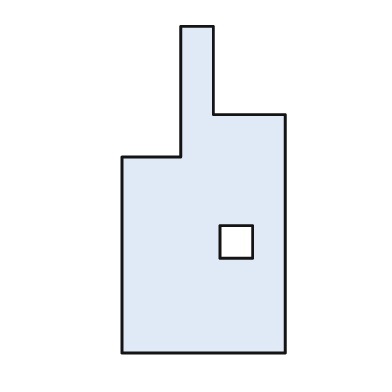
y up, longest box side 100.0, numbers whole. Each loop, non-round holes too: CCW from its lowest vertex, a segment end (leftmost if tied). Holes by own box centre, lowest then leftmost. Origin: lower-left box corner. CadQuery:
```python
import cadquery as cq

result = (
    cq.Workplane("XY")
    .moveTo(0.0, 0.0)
    .lineTo(50.0, 0.0)
    .lineTo(50.0, 73.0)
    .lineTo(28.0, 73.0)
    .lineTo(28.0, 100.0)
    .lineTo(18.0, 100.0)
    .lineTo(18.0, 60.0)
    .lineTo(0.0, 60.0)
    .close()
    .moveTo(30.0, 29.0)
    .lineTo(40.0, 29.0)
    .lineTo(40.0, 39.0)
    .lineTo(30.0, 39.0)
    .close()
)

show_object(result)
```